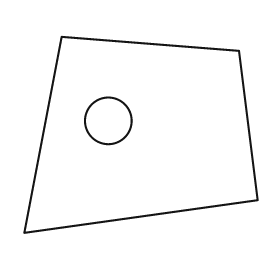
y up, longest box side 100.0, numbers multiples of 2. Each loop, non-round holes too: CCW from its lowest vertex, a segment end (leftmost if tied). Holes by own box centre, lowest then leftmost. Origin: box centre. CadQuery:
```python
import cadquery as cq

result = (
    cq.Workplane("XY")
    .moveTo(-50.0, -42.0)
    .lineTo(50.0, -28.0)
    .lineTo(42.0, 36.0)
    .lineTo(-34.0, 42.0)
    .close()
    .moveTo(-14.0, 6.0)
    .circle(10.0)
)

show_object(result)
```